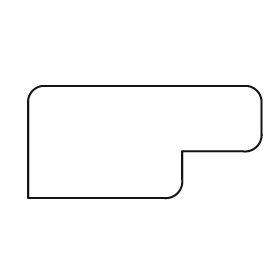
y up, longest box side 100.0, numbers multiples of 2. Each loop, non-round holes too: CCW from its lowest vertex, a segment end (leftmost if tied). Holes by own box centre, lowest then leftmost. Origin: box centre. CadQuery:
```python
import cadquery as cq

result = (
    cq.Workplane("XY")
    .moveTo(-50.0, -24.0)
    .lineTo(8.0, -24.0)
    .threePointArc((14.0, -22.0), (16.0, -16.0))
    .lineTo(16.0, -4.0)
    .lineTo(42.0, -4.0)
    .threePointArc((48.0, -2.0), (50.0, 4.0))
    .lineTo(50.0, 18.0)
    .threePointArc((48.0, 22.0), (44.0, 24.0))
    .lineTo(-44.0, 24.0)
    .threePointArc((-48.0, 22.0), (-50.0, 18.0))
    .close()
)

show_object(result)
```